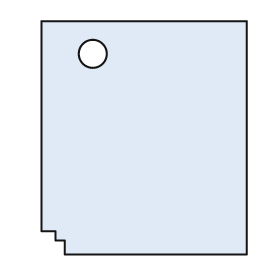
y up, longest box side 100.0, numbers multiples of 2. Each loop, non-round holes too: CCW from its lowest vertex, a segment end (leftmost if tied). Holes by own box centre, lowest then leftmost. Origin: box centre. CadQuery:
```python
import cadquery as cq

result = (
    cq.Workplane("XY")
    .moveTo(-34.0, -50.0)
    .lineTo(44.0, -50.0)
    .lineTo(44.0, 50.0)
    .lineTo(-44.0, 50.0)
    .lineTo(-44.0, -40.0)
    .lineTo(-38.0, -40.0)
    .lineTo(-38.0, -44.0)
    .lineTo(-34.0, -44.0)
    .close()
    .moveTo(-22.0, 36.0)
    .circle(6.0)
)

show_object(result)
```